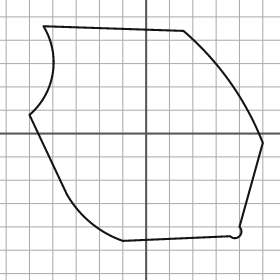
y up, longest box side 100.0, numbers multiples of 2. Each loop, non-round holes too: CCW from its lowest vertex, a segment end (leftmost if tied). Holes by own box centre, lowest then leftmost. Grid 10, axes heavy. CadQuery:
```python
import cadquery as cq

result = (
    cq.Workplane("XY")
    .moveTo(-10.0, -46.0)
    .lineTo(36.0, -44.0)
    .threePointArc((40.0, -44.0), (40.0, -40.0))
    .lineTo(50.0, -4.0)
    .threePointArc((36.0, 22.0), (16.0, 44.0))
    .lineTo(-44.0, 46.0)
    .threePointArc((-40.0, 26.0), (-50.0, 8.0))
    .lineTo(-34.0, -26.0)
    .threePointArc((-24.0, -38.0), (-10.0, -46.0))
    .close()
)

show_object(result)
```